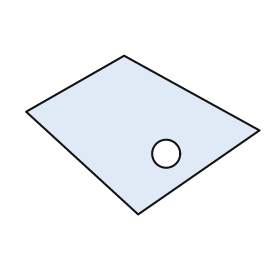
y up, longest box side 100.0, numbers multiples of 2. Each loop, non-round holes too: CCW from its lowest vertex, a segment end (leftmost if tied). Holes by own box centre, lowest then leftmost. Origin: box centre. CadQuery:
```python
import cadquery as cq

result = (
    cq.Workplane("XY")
    .moveTo(-2.0, -34.0)
    .lineTo(50.0, 2.0)
    .lineTo(-8.0, 34.0)
    .lineTo(-50.0, 10.0)
    .close()
    .moveTo(10.0, -8.0)
    .circle(6.0)
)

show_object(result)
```